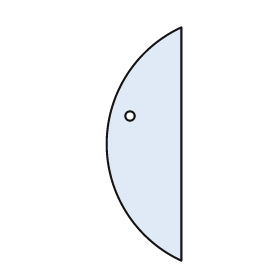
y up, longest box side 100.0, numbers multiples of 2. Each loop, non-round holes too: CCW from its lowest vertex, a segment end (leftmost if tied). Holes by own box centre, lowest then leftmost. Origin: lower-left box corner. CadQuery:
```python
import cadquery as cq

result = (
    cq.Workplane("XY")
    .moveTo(32.0, 0.0)
    .lineTo(32.0, 100.0)
    .threePointArc((0.0, 50.0), (32.0, 0.0))
    .close()
    .moveTo(10.0, 62.0)
    .circle(2.0)
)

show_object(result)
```